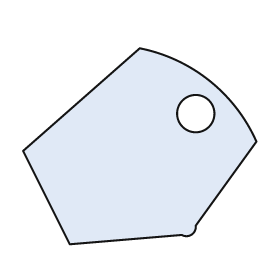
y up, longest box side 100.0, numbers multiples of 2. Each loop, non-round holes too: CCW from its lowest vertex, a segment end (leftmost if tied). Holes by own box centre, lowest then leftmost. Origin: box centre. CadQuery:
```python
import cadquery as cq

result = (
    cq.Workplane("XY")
    .moveTo(-30.0, -42.0)
    .lineTo(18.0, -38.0)
    .threePointArc((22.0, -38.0), (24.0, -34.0))
    .lineTo(50.0, 2.0)
    .threePointArc((30.0, 28.0), (0.0, 42.0))
    .lineTo(-50.0, -2.0)
    .close()
    .moveTo(24.0, 14.0)
    .circle(8.0)
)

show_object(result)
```